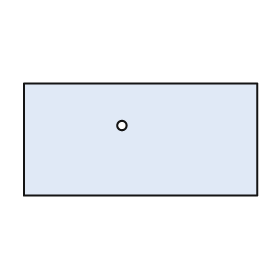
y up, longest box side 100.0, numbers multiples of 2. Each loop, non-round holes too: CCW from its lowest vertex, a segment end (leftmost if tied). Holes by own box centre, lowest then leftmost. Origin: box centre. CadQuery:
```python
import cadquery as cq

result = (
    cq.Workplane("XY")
    .moveTo(-50.0, -24.0)
    .lineTo(50.0, -24.0)
    .lineTo(50.0, 24.0)
    .lineTo(-50.0, 24.0)
    .close()
    .moveTo(-8.0, 6.0)
    .circle(2.0)
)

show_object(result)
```